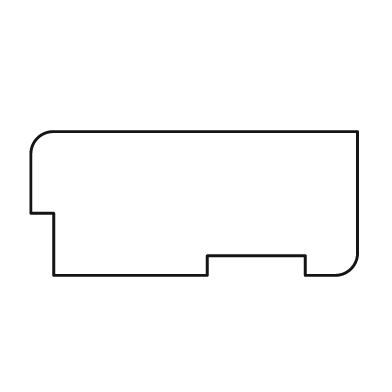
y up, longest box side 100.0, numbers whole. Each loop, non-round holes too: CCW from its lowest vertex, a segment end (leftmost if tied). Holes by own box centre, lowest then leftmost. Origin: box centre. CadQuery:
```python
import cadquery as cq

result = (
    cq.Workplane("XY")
    .moveTo(-43.0, -22.0)
    .lineTo(4.0, -22.0)
    .lineTo(4.0, -16.0)
    .lineTo(34.0, -16.0)
    .lineTo(34.0, -22.0)
    .lineTo(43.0, -22.0)
    .threePointArc((48.0, -20.0), (50.0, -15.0))
    .lineTo(50.0, 22.0)
    .lineTo(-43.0, 22.0)
    .threePointArc((-48.0, 20.0), (-50.0, 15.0))
    .lineTo(-50.0, -3.0)
    .lineTo(-43.0, -3.0)
    .close()
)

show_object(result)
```